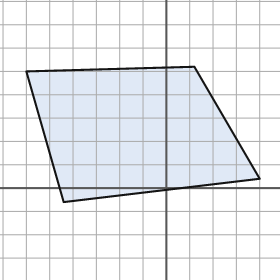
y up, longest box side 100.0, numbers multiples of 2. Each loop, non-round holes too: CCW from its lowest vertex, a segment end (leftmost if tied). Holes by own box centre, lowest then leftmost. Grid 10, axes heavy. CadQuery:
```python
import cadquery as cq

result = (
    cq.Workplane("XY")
    .moveTo(-44.0, -6.0)
    .lineTo(40.0, 4.0)
    .lineTo(12.0, 52.0)
    .lineTo(-60.0, 50.0)
    .close()
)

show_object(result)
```